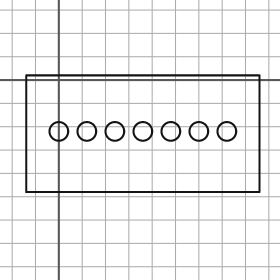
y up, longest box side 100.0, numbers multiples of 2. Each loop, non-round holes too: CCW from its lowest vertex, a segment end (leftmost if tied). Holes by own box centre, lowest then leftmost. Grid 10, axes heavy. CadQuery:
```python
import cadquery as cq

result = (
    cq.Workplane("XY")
    .moveTo(-14.0, -48.0)
    .lineTo(86.0, -48.0)
    .lineTo(86.0, 2.0)
    .lineTo(-14.0, 2.0)
    .close()
    .moveTo(0.0, -22.0)
    .circle(4.0)
    .moveTo(12.0, -22.0)
    .circle(4.0)
    .moveTo(24.0, -22.0)
    .circle(4.0)
    .moveTo(36.0, -22.0)
    .circle(4.0)
    .moveTo(48.0, -22.0)
    .circle(4.0)
    .moveTo(60.0, -22.0)
    .circle(4.0)
    .moveTo(72.0, -22.0)
    .circle(4.0)
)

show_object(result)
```